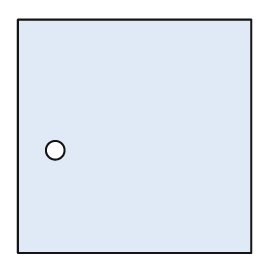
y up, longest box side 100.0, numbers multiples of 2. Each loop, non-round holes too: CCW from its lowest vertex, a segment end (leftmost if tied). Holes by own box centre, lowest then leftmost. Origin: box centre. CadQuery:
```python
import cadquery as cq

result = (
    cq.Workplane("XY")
    .moveTo(-50.0, -50.0)
    .lineTo(50.0, -50.0)
    .lineTo(50.0, 50.0)
    .lineTo(-50.0, 50.0)
    .close()
    .moveTo(-34.0, -6.0)
    .circle(4.0)
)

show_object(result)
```